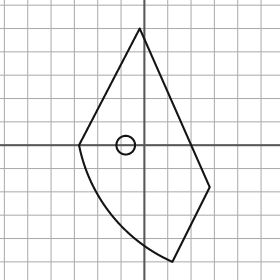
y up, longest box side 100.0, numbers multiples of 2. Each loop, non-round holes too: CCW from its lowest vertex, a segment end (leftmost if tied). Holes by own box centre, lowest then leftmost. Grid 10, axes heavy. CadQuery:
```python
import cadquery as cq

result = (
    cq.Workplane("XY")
    .moveTo(12.0, -50.0)
    .lineTo(28.0, -18.0)
    .lineTo(-2.0, 50.0)
    .lineTo(-28.0, 0.0)
    .threePointArc((-14.0, -30.0), (12.0, -50.0))
    .close()
    .moveTo(-8.0, 0.0)
    .circle(4.0)
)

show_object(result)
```